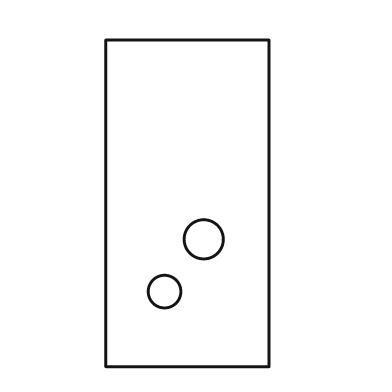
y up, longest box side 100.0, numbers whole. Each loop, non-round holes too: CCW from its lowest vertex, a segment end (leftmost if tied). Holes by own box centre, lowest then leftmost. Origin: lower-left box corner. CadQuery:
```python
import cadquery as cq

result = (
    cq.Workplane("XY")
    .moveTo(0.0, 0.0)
    .lineTo(50.0, 0.0)
    .lineTo(50.0, 100.0)
    .lineTo(0.0, 100.0)
    .close()
    .moveTo(18.0, 23.0)
    .circle(5.0)
    .moveTo(30.0, 39.0)
    .circle(6.0)
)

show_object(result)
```